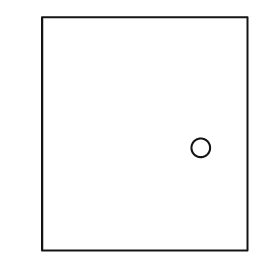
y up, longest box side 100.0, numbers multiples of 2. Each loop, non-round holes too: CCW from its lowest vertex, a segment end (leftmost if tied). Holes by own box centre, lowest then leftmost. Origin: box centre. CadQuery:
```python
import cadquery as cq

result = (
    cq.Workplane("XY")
    .moveTo(-44.0, -50.0)
    .lineTo(44.0, -50.0)
    .lineTo(44.0, 50.0)
    .lineTo(-44.0, 50.0)
    .close()
    .moveTo(24.0, -6.0)
    .circle(4.0)
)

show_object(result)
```